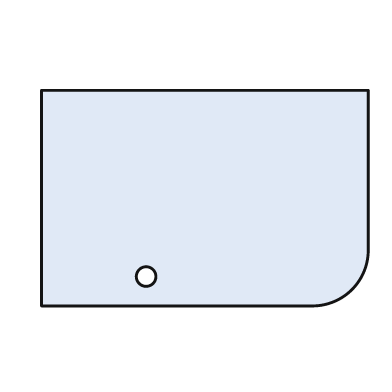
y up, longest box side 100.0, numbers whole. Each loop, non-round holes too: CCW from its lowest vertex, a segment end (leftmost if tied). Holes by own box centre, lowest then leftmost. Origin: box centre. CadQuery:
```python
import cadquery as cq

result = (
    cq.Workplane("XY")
    .moveTo(-50.0, -33.0)
    .lineTo(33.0, -33.0)
    .threePointArc((45.0, -28.0), (50.0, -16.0))
    .lineTo(50.0, 33.0)
    .lineTo(-50.0, 33.0)
    .close()
    .moveTo(-18.0, -24.0)
    .circle(3.0)
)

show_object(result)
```